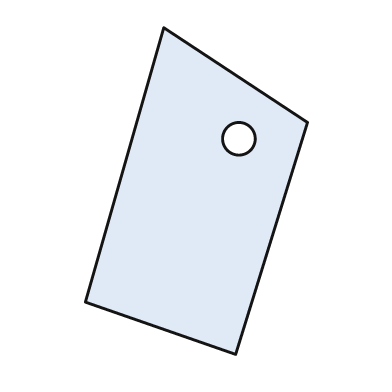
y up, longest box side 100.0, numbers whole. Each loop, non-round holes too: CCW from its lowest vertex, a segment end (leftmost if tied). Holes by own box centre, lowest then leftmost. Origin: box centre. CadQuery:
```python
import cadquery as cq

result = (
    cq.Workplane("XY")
    .moveTo(12.0, -50.0)
    .lineTo(34.0, 21.0)
    .lineTo(-10.0, 50.0)
    .lineTo(-34.0, -34.0)
    .close()
    .moveTo(13.0, 16.0)
    .circle(5.0)
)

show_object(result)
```